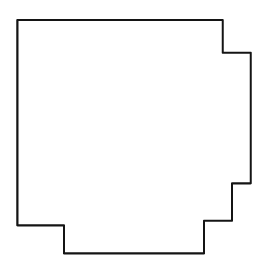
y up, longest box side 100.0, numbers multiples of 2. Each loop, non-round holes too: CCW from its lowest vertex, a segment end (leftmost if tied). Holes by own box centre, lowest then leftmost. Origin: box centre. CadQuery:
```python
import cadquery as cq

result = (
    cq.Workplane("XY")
    .moveTo(-30.0, -50.0)
    .lineTo(30.0, -50.0)
    .lineTo(30.0, -36.0)
    .lineTo(42.0, -36.0)
    .lineTo(42.0, -20.0)
    .lineTo(50.0, -20.0)
    .lineTo(50.0, 36.0)
    .lineTo(38.0, 36.0)
    .lineTo(38.0, 50.0)
    .lineTo(-50.0, 50.0)
    .lineTo(-50.0, -38.0)
    .lineTo(-30.0, -38.0)
    .close()
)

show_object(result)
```